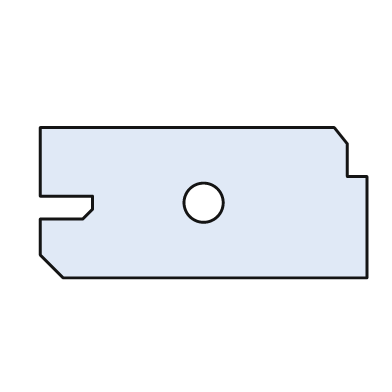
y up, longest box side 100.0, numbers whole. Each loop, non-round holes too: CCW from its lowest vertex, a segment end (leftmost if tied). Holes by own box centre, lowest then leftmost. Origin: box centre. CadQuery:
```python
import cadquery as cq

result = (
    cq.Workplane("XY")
    .moveTo(-43.0, -23.0)
    .lineTo(50.0, -23.0)
    .lineTo(50.0, 8.0)
    .lineTo(44.0, 8.0)
    .lineTo(44.0, 18.0)
    .lineTo(40.0, 23.0)
    .lineTo(-50.0, 23.0)
    .lineTo(-50.0, 2.0)
    .lineTo(-34.0, 2.0)
    .lineTo(-34.0, -2.0)
    .lineTo(-37.0, -5.0)
    .lineTo(-50.0, -5.0)
    .lineTo(-50.0, -16.0)
    .close()
    .moveTo(0.0, 0.0)
    .circle(6.0)
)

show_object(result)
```